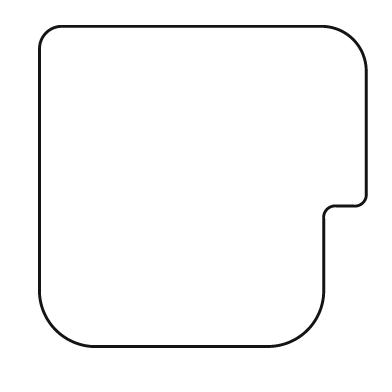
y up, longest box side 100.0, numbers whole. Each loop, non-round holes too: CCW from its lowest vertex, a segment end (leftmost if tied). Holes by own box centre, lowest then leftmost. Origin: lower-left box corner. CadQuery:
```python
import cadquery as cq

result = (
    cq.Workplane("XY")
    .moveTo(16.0, 0.0)
    .lineTo(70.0, 0.0)
    .threePointArc((82.0, 5.0), (87.0, 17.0))
    .lineTo(87.0, 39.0)
    .threePointArc((88.0, 42.0), (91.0, 43.0))
    .lineTo(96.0, 43.0)
    .threePointArc((99.0, 44.0), (100.0, 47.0))
    .lineTo(100.0, 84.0)
    .threePointArc((96.0, 94.0), (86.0, 98.0))
    .lineTo(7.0, 98.0)
    .threePointArc((2.0, 96.0), (0.0, 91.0))
    .lineTo(0.0, 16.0)
    .threePointArc((5.0, 5.0), (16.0, 0.0))
    .close()
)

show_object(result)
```